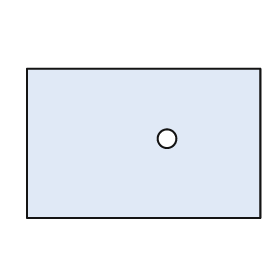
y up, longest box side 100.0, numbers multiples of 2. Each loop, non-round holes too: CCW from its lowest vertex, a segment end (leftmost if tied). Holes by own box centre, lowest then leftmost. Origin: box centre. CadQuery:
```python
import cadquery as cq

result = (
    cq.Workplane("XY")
    .moveTo(-50.0, -32.0)
    .lineTo(50.0, -32.0)
    .lineTo(50.0, 32.0)
    .lineTo(-50.0, 32.0)
    .close()
    .moveTo(10.0, 2.0)
    .circle(4.0)
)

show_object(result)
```